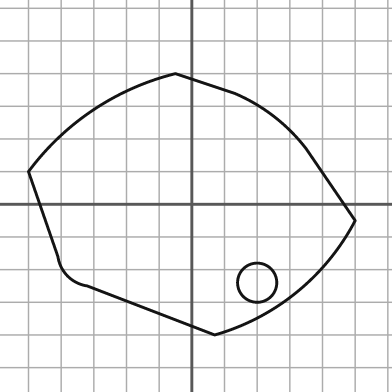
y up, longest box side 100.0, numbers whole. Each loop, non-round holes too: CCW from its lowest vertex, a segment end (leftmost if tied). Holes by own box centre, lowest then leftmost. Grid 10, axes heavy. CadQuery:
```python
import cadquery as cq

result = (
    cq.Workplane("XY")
    .moveTo(7.0, -40.0)
    .threePointArc((32.0, -27.0), (50.0, -5.0))
    .lineTo(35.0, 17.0)
    .threePointArc((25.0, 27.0), (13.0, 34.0))
    .lineTo(-5.0, 40.0)
    .threePointArc((-30.0, 29.0), (-50.0, 10.0))
    .lineTo(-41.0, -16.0)
    .threePointArc((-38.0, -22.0), (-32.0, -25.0))
    .close()
    .moveTo(20.0, -24.0)
    .circle(6.0)
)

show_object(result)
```